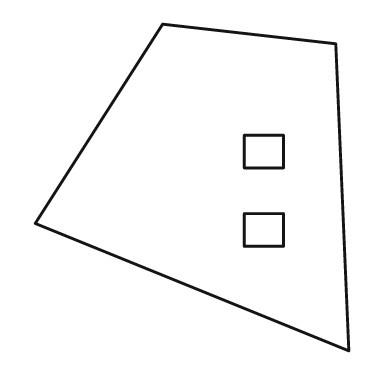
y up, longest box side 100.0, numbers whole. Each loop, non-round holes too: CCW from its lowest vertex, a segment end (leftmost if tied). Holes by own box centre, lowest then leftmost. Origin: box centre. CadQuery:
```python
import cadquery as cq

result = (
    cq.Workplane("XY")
    .moveTo(48.0, -50.0)
    .lineTo(44.0, 44.0)
    .lineTo(-9.0, 50.0)
    .lineTo(-48.0, -11.0)
    .close()
    .moveTo(16.0, -18.0)
    .lineTo(28.0, -18.0)
    .lineTo(28.0, -8.0)
    .lineTo(16.0, -8.0)
    .close()
    .moveTo(16.0, 6.0)
    .lineTo(28.0, 6.0)
    .lineTo(28.0, 16.0)
    .lineTo(16.0, 16.0)
    .close()
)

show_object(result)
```